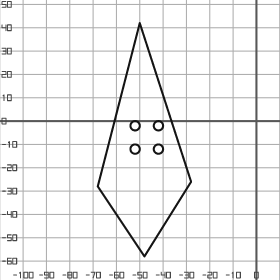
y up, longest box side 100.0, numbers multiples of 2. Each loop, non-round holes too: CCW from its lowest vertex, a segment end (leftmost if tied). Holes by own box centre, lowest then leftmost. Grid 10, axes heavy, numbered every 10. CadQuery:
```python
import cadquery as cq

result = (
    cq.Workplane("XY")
    .moveTo(-48.0, -58.0)
    .lineTo(-28.0, -26.0)
    .lineTo(-50.0, 42.0)
    .lineTo(-68.0, -28.0)
    .close()
    .moveTo(-52.0, -12.0)
    .circle(2.0)
    .moveTo(-42.0, -12.0)
    .circle(2.0)
    .moveTo(-52.0, -2.0)
    .circle(2.0)
    .moveTo(-42.0, -2.0)
    .circle(2.0)
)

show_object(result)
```